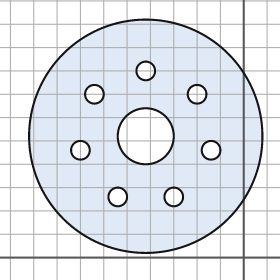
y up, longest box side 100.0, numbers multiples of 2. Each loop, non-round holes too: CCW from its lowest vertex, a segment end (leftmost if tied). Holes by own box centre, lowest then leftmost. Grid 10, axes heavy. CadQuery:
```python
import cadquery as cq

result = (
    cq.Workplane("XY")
    .moveTo(-42.0, 52.0)
    .circle(50.0)
    .moveTo(-54.0, 26.0)
    .circle(4.0)
    .moveTo(-30.0, 26.0)
    .circle(4.0)
    .moveTo(-70.0, 46.0)
    .circle(4.0)
    .moveTo(-14.0, 46.0)
    .circle(4.0)
    .moveTo(-42.0, 52.0)
    .circle(12.0)
    .moveTo(-64.0, 70.0)
    .circle(4.0)
    .moveTo(-20.0, 70.0)
    .circle(4.0)
    .moveTo(-42.0, 80.0)
    .circle(4.0)
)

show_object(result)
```